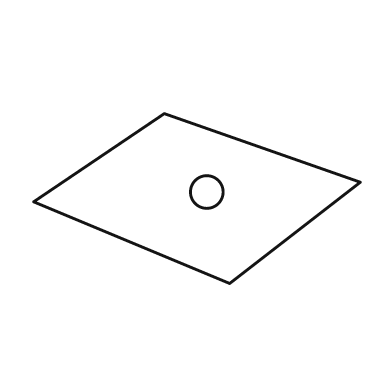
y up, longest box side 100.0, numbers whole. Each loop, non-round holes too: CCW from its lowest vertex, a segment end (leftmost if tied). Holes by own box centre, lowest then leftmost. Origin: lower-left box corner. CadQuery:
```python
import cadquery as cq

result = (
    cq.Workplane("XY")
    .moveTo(60.0, 0.0)
    .lineTo(100.0, 31.0)
    .lineTo(40.0, 52.0)
    .lineTo(0.0, 25.0)
    .close()
    .moveTo(53.0, 28.0)
    .circle(5.0)
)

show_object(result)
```